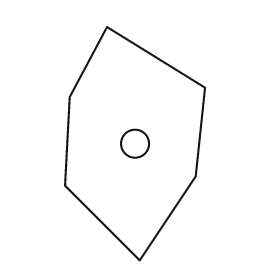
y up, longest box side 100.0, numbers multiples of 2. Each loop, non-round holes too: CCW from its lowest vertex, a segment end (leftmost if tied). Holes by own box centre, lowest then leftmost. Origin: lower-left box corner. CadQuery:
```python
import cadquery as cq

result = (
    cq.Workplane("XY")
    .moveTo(32.0, 0.0)
    .lineTo(56.0, 36.0)
    .lineTo(60.0, 74.0)
    .lineTo(18.0, 100.0)
    .lineTo(2.0, 70.0)
    .lineTo(0.0, 32.0)
    .close()
    .moveTo(30.0, 50.0)
    .circle(6.0)
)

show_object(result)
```